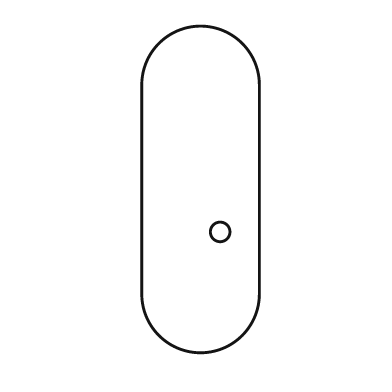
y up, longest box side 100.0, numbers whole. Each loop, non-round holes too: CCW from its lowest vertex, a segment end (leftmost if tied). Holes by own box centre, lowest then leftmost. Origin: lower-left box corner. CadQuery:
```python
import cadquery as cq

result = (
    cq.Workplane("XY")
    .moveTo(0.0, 18.0)
    .threePointArc((18.0, 0.0), (36.0, 18.0))
    .lineTo(36.0, 82.0)
    .threePointArc((18.0, 100.0), (0.0, 82.0))
    .close()
    .moveTo(24.0, 37.0)
    .circle(3.0)
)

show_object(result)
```